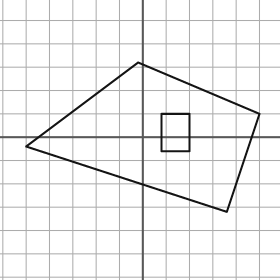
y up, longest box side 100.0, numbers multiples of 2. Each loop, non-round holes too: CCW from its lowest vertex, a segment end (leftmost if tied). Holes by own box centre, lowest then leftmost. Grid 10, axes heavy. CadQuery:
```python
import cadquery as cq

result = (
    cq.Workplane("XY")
    .moveTo(36.0, -32.0)
    .lineTo(50.0, 10.0)
    .lineTo(-2.0, 32.0)
    .lineTo(-50.0, -4.0)
    .close()
    .moveTo(8.0, -6.0)
    .lineTo(20.0, -6.0)
    .lineTo(20.0, 10.0)
    .lineTo(8.0, 10.0)
    .close()
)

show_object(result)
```